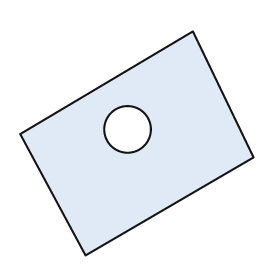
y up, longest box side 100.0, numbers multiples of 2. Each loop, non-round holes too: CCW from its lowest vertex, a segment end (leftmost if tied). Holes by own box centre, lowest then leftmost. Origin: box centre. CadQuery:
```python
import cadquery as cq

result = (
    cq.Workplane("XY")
    .moveTo(-22.0, -48.0)
    .lineTo(50.0, -6.0)
    .lineTo(24.0, 48.0)
    .lineTo(-50.0, 4.0)
    .close()
    .moveTo(-4.0, 6.0)
    .circle(10.0)
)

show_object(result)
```